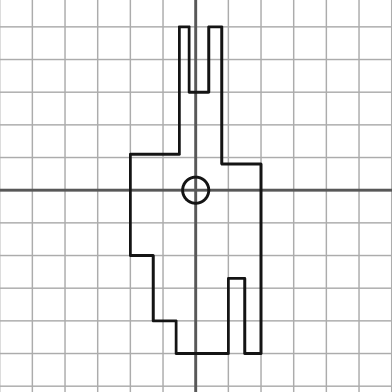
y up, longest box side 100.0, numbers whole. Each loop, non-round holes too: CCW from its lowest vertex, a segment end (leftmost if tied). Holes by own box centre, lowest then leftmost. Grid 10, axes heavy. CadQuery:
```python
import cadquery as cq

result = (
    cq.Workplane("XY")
    .moveTo(-6.0, -50.0)
    .lineTo(10.0, -50.0)
    .lineTo(10.0, -27.0)
    .lineTo(15.0, -27.0)
    .lineTo(15.0, -50.0)
    .lineTo(20.0, -50.0)
    .lineTo(20.0, 8.0)
    .lineTo(8.0, 8.0)
    .lineTo(8.0, 50.0)
    .lineTo(4.0, 50.0)
    .lineTo(4.0, 30.0)
    .lineTo(-2.0, 30.0)
    .lineTo(-2.0, 50.0)
    .lineTo(-5.0, 50.0)
    .lineTo(-5.0, 11.0)
    .lineTo(-20.0, 11.0)
    .lineTo(-20.0, -20.0)
    .lineTo(-13.0, -20.0)
    .lineTo(-13.0, -40.0)
    .lineTo(-6.0, -40.0)
    .close()
    .moveTo(0.0, 0.0)
    .circle(4.0)
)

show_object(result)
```